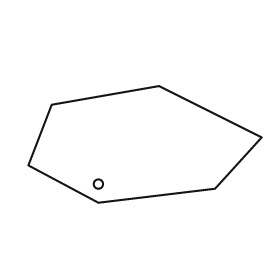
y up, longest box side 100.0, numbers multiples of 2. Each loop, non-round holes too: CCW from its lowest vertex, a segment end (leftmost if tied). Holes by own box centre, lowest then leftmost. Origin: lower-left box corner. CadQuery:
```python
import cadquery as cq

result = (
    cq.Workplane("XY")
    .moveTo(30.0, 0.0)
    .lineTo(80.0, 6.0)
    .lineTo(100.0, 28.0)
    .lineTo(56.0, 50.0)
    .lineTo(10.0, 42.0)
    .lineTo(0.0, 16.0)
    .close()
    .moveTo(30.0, 8.0)
    .circle(2.0)
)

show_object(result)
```